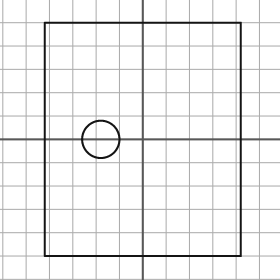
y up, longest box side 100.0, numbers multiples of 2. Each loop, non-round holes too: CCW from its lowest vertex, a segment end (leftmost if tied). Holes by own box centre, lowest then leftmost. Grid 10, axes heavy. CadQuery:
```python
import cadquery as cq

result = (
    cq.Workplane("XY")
    .moveTo(-42.0, -50.0)
    .lineTo(42.0, -50.0)
    .lineTo(42.0, 50.0)
    .lineTo(-42.0, 50.0)
    .close()
    .moveTo(-18.0, 0.0)
    .circle(8.0)
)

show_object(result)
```